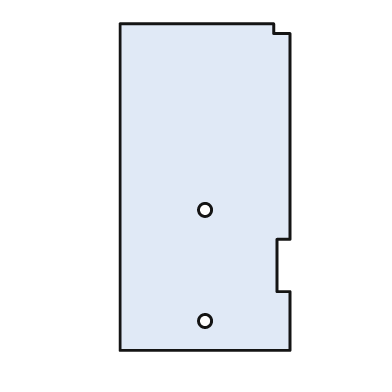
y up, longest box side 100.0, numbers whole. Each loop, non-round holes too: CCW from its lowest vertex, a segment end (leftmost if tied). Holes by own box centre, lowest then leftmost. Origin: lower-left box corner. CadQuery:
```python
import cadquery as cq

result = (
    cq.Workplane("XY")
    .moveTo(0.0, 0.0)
    .lineTo(52.0, 0.0)
    .lineTo(52.0, 18.0)
    .lineTo(48.0, 18.0)
    .lineTo(48.0, 34.0)
    .lineTo(52.0, 34.0)
    .lineTo(52.0, 97.0)
    .lineTo(47.0, 97.0)
    .lineTo(47.0, 100.0)
    .lineTo(0.0, 100.0)
    .close()
    .moveTo(26.0, 9.0)
    .circle(2.0)
    .moveTo(26.0, 43.0)
    .circle(2.0)
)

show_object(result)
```